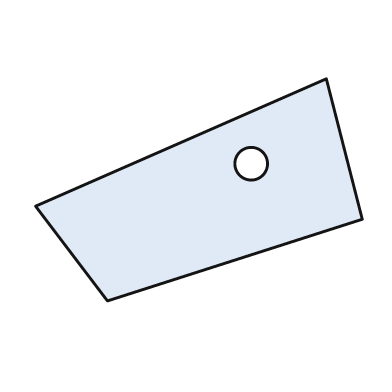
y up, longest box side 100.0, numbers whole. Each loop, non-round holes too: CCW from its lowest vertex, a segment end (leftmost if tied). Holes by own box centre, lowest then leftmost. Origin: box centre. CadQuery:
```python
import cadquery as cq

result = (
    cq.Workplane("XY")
    .moveTo(-28.0, -34.0)
    .lineTo(50.0, -9.0)
    .lineTo(39.0, 34.0)
    .lineTo(-50.0, -5.0)
    .close()
    .moveTo(16.0, 8.0)
    .circle(5.0)
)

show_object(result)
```